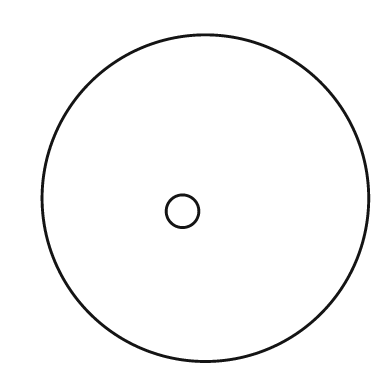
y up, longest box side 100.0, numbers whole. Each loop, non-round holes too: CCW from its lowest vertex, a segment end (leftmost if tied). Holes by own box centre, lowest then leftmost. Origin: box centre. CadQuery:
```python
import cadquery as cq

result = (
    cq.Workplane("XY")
    .moveTo(0.0, 0.0)
    .circle(50.0)
    .moveTo(-7.0, -4.0)
    .circle(5.0)
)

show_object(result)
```